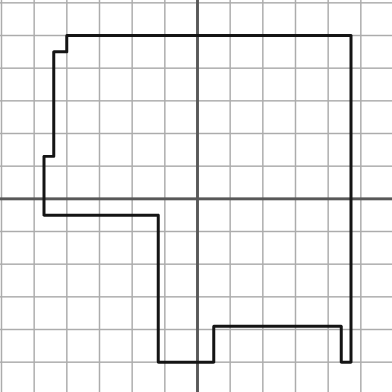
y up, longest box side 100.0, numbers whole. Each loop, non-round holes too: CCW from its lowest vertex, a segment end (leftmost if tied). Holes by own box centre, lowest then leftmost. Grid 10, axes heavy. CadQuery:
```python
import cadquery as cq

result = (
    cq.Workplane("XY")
    .moveTo(-12.0, -50.0)
    .lineTo(5.0, -50.0)
    .lineTo(5.0, -39.0)
    .lineTo(44.0, -39.0)
    .lineTo(44.0, -50.0)
    .lineTo(47.0, -50.0)
    .lineTo(47.0, 50.0)
    .lineTo(-40.0, 50.0)
    .lineTo(-40.0, 45.0)
    .lineTo(-44.0, 45.0)
    .lineTo(-44.0, 13.0)
    .lineTo(-47.0, 13.0)
    .lineTo(-47.0, -5.0)
    .lineTo(-12.0, -5.0)
    .close()
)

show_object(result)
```